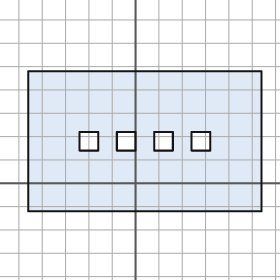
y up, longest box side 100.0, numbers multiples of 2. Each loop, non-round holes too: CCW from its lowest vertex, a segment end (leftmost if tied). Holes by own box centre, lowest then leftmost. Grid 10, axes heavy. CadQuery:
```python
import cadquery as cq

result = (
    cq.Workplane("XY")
    .moveTo(-46.0, -12.0)
    .lineTo(54.0, -12.0)
    .lineTo(54.0, 48.0)
    .lineTo(-46.0, 48.0)
    .close()
    .moveTo(-24.0, 14.0)
    .lineTo(-16.0, 14.0)
    .lineTo(-16.0, 22.0)
    .lineTo(-24.0, 22.0)
    .close()
    .moveTo(-8.0, 14.0)
    .lineTo(0.0, 14.0)
    .lineTo(0.0, 22.0)
    .lineTo(-8.0, 22.0)
    .close()
    .moveTo(8.0, 14.0)
    .lineTo(16.0, 14.0)
    .lineTo(16.0, 22.0)
    .lineTo(8.0, 22.0)
    .close()
    .moveTo(24.0, 14.0)
    .lineTo(32.0, 14.0)
    .lineTo(32.0, 22.0)
    .lineTo(24.0, 22.0)
    .close()
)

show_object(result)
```